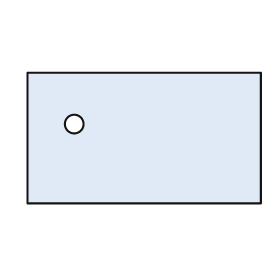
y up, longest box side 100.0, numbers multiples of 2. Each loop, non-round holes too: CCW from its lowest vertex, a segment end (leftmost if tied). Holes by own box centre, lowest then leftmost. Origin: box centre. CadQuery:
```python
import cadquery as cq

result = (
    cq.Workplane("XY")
    .moveTo(-50.0, -28.0)
    .lineTo(50.0, -28.0)
    .lineTo(50.0, 28.0)
    .lineTo(-50.0, 28.0)
    .close()
    .moveTo(-30.0, 6.0)
    .circle(4.0)
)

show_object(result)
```